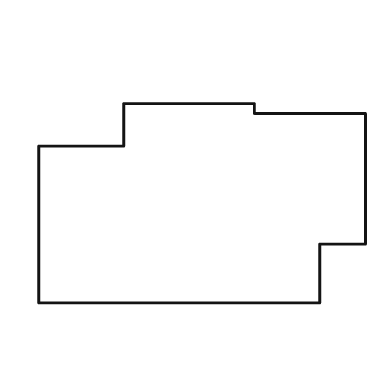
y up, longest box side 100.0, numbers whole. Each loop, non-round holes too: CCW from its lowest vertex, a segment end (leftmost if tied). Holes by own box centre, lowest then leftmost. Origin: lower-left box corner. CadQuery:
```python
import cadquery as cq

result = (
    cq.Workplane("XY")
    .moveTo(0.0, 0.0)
    .lineTo(86.0, 0.0)
    .lineTo(86.0, 18.0)
    .lineTo(100.0, 18.0)
    .lineTo(100.0, 58.0)
    .lineTo(66.0, 58.0)
    .lineTo(66.0, 61.0)
    .lineTo(26.0, 61.0)
    .lineTo(26.0, 48.0)
    .lineTo(0.0, 48.0)
    .close()
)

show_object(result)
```